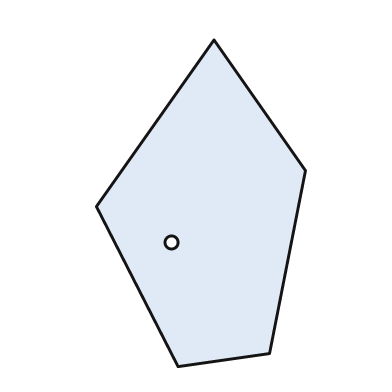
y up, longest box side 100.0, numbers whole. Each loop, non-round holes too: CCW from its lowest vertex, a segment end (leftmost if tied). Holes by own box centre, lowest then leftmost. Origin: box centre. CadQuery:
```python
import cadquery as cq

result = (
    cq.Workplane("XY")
    .moveTo(-7.0, -50.0)
    .lineTo(21.0, -46.0)
    .lineTo(32.0, 10.0)
    .lineTo(4.0, 50.0)
    .lineTo(-32.0, -1.0)
    .close()
    .moveTo(-9.0, -12.0)
    .circle(2.0)
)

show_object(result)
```